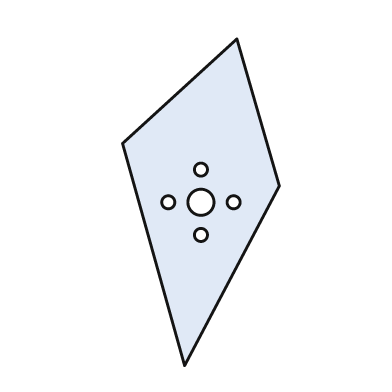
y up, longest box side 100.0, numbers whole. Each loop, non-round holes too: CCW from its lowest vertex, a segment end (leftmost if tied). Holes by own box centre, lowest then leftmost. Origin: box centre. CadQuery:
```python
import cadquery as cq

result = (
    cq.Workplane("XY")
    .moveTo(-5.0, -50.0)
    .lineTo(24.0, 5.0)
    .lineTo(11.0, 50.0)
    .lineTo(-24.0, 18.0)
    .close()
    .moveTo(0.0, -10.0)
    .circle(2.0)
    .moveTo(-10.0, 0.0)
    .circle(2.0)
    .moveTo(0.0, 0.0)
    .circle(4.0)
    .moveTo(10.0, 0.0)
    .circle(2.0)
    .moveTo(0.0, 10.0)
    .circle(2.0)
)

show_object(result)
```